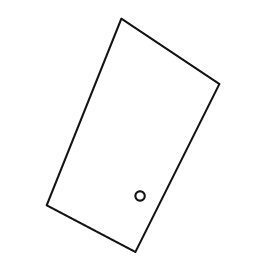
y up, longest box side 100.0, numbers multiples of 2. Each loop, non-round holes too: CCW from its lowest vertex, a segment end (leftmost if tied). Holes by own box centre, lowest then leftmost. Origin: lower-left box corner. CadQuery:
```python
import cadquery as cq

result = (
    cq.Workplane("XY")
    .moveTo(38.0, 0.0)
    .lineTo(74.0, 72.0)
    .lineTo(32.0, 100.0)
    .lineTo(0.0, 20.0)
    .close()
    .moveTo(40.0, 24.0)
    .circle(2.0)
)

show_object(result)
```